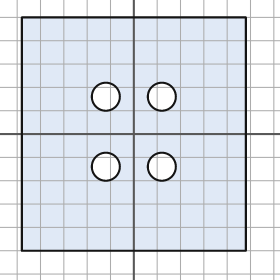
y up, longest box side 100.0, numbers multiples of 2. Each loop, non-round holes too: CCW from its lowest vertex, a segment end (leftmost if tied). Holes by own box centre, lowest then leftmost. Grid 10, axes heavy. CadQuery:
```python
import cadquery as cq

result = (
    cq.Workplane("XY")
    .moveTo(-48.0, -50.0)
    .lineTo(48.0, -50.0)
    .lineTo(48.0, 50.0)
    .lineTo(-48.0, 50.0)
    .close()
    .moveTo(-12.0, -14.0)
    .circle(6.0)
    .moveTo(12.0, -14.0)
    .circle(6.0)
    .moveTo(-12.0, 16.0)
    .circle(6.0)
    .moveTo(12.0, 16.0)
    .circle(6.0)
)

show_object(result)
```